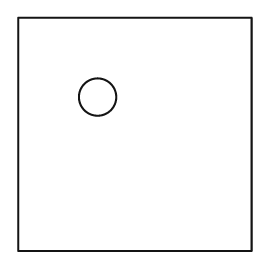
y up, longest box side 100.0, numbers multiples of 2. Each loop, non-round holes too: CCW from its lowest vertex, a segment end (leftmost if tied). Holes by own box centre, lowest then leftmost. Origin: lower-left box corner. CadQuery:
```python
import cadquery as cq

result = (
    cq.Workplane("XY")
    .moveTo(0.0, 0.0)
    .lineTo(100.0, 0.0)
    .lineTo(100.0, 100.0)
    .lineTo(0.0, 100.0)
    .close()
    .moveTo(34.0, 66.0)
    .circle(8.0)
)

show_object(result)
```